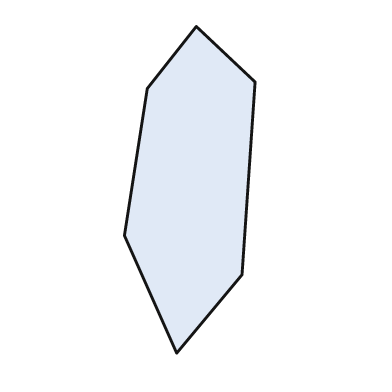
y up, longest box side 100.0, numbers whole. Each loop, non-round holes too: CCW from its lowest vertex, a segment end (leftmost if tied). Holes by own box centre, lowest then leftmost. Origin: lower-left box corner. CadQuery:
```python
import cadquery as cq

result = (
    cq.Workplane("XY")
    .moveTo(16.0, 0.0)
    .lineTo(36.0, 24.0)
    .lineTo(40.0, 83.0)
    .lineTo(22.0, 100.0)
    .lineTo(7.0, 81.0)
    .lineTo(0.0, 36.0)
    .close()
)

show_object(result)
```